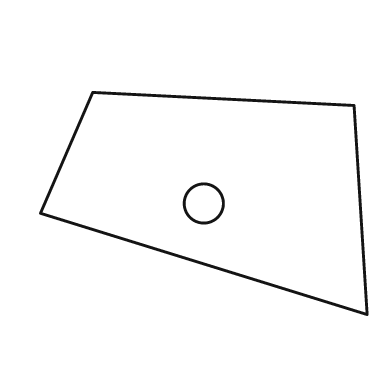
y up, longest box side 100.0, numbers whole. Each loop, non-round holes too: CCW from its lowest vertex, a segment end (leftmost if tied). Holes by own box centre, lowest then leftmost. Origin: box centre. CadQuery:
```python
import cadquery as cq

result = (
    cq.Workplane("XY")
    .moveTo(50.0, -34.0)
    .lineTo(46.0, 30.0)
    .lineTo(-34.0, 34.0)
    .lineTo(-50.0, -3.0)
    .close()
    .moveTo(0.0, 0.0)
    .circle(6.0)
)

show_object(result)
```